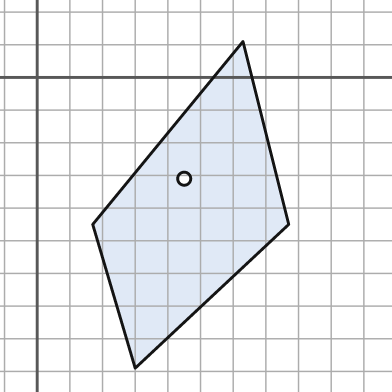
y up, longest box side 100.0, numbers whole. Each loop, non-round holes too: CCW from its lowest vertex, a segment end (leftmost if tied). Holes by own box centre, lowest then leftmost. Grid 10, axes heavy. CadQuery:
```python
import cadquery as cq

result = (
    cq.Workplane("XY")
    .moveTo(30.0, -89.0)
    .lineTo(77.0, -45.0)
    .lineTo(63.0, 11.0)
    .lineTo(17.0, -45.0)
    .close()
    .moveTo(45.0, -31.0)
    .circle(2.0)
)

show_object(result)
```